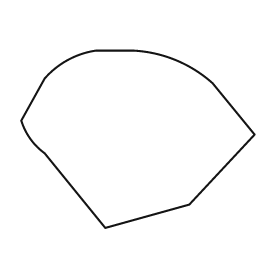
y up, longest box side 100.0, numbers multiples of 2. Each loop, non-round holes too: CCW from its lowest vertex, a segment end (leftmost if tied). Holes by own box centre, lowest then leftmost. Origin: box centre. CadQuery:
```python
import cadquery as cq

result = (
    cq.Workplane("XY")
    .moveTo(-14.0, -38.0)
    .lineTo(22.0, -28.0)
    .lineTo(50.0, 2.0)
    .lineTo(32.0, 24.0)
    .threePointArc((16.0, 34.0), (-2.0, 38.0))
    .lineTo(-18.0, 38.0)
    .threePointArc((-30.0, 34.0), (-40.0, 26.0))
    .lineTo(-50.0, 8.0)
    .threePointArc((-46.0, 0.0), (-40.0, -6.0))
    .close()
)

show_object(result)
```